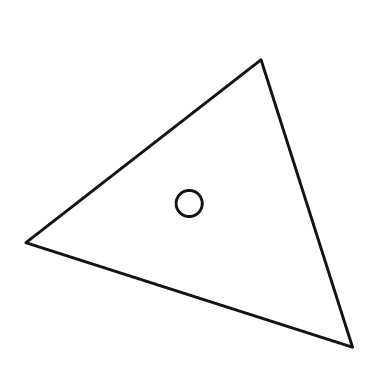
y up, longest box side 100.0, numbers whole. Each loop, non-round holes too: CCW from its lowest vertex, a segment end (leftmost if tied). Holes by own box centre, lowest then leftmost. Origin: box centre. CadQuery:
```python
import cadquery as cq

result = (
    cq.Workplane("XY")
    .moveTo(50.0, -44.0)
    .lineTo(22.0, 44.0)
    .lineTo(-50.0, -12.0)
    .close()
    .moveTo(0.0, 0.0)
    .circle(4.0)
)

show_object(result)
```